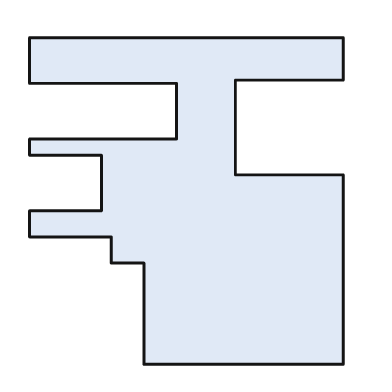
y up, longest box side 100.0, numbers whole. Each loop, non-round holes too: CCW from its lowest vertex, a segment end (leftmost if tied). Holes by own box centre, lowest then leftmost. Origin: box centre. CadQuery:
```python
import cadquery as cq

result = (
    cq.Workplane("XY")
    .moveTo(-13.0, -50.0)
    .lineTo(48.0, -50.0)
    .lineTo(48.0, 8.0)
    .lineTo(15.0, 8.0)
    .lineTo(15.0, 37.0)
    .lineTo(48.0, 37.0)
    .lineTo(48.0, 50.0)
    .lineTo(-48.0, 50.0)
    .lineTo(-48.0, 36.0)
    .lineTo(-3.0, 36.0)
    .lineTo(-3.0, 19.0)
    .lineTo(-48.0, 19.0)
    .lineTo(-48.0, 14.0)
    .lineTo(-26.0, 14.0)
    .lineTo(-26.0, -3.0)
    .lineTo(-48.0, -3.0)
    .lineTo(-48.0, -11.0)
    .lineTo(-23.0, -11.0)
    .lineTo(-23.0, -19.0)
    .lineTo(-13.0, -19.0)
    .close()
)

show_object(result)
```